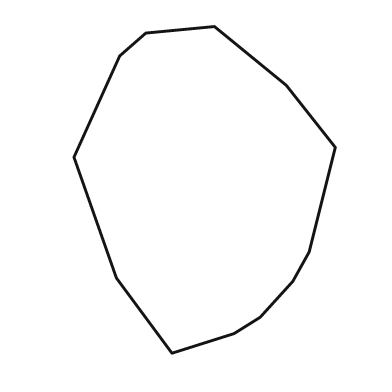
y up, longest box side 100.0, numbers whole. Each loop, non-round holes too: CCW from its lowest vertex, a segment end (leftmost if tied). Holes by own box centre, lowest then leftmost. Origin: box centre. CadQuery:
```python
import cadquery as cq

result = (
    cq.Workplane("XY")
    .moveTo(-10.0, -50.0)
    .lineTo(9.0, -44.0)
    .lineTo(17.0, -39.0)
    .lineTo(27.0, -28.0)
    .lineTo(32.0, -19.0)
    .lineTo(40.0, 13.0)
    .lineTo(25.0, 32.0)
    .lineTo(3.0, 50.0)
    .lineTo(-18.0, 48.0)
    .lineTo(-26.0, 41.0)
    .lineTo(-40.0, 10.0)
    .lineTo(-27.0, -27.0)
    .close()
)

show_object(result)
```